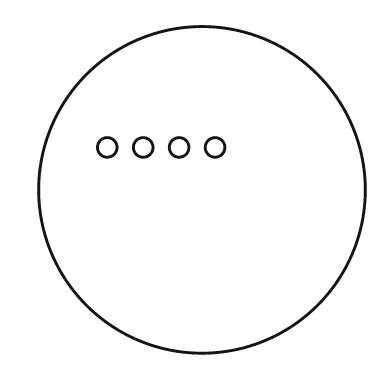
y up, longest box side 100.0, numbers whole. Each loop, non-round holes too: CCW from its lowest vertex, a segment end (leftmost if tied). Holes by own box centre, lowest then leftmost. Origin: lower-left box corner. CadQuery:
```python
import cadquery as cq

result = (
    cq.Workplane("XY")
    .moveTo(50.0, 50.0)
    .circle(50.0)
    .moveTo(21.0, 63.0)
    .circle(3.0)
    .moveTo(32.0, 63.0)
    .circle(3.0)
    .moveTo(43.0, 63.0)
    .circle(3.0)
    .moveTo(54.0, 63.0)
    .circle(3.0)
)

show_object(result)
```